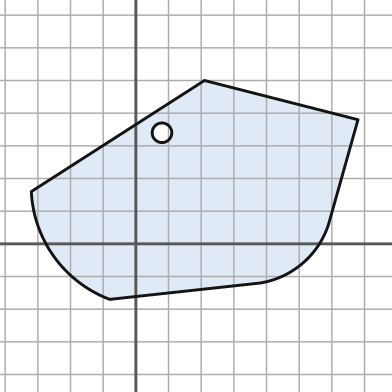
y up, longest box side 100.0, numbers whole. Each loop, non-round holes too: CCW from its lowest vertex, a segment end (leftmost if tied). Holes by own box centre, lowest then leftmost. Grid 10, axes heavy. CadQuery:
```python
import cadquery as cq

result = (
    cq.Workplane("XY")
    .moveTo(-8.0, -17.0)
    .lineTo(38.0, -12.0)
    .threePointArc((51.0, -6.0), (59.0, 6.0))
    .lineTo(68.0, 38.0)
    .lineTo(21.0, 50.0)
    .lineTo(-32.0, 16.0)
    .threePointArc((-25.0, -4.0), (-8.0, -17.0))
    .close()
    .moveTo(8.0, 34.0)
    .circle(3.0)
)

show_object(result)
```